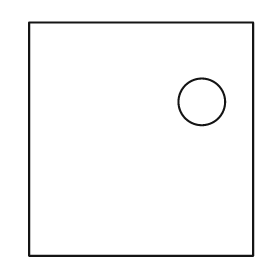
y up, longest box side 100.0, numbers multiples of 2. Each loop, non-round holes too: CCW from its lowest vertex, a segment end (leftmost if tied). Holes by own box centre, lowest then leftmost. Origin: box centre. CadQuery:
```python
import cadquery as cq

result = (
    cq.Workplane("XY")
    .moveTo(-48.0, -50.0)
    .lineTo(48.0, -50.0)
    .lineTo(48.0, 50.0)
    .lineTo(-48.0, 50.0)
    .close()
    .moveTo(26.0, 16.0)
    .circle(10.0)
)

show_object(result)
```